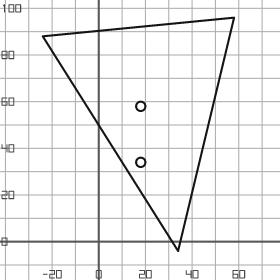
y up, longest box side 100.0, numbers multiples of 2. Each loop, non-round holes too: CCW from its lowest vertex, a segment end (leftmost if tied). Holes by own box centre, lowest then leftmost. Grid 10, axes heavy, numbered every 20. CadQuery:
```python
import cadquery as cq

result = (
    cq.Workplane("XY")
    .moveTo(34.0, -4.0)
    .lineTo(58.0, 96.0)
    .lineTo(-24.0, 88.0)
    .close()
    .moveTo(18.0, 34.0)
    .circle(2.0)
    .moveTo(18.0, 58.0)
    .circle(2.0)
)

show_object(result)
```